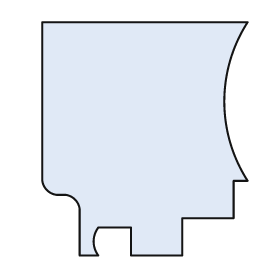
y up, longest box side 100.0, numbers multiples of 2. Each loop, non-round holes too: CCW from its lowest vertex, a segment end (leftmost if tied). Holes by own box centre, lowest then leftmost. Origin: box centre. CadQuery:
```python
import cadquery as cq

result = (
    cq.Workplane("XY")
    .moveTo(-28.0, -50.0)
    .lineTo(-20.0, -50.0)
    .threePointArc((-22.0, -44.0), (-20.0, -38.0))
    .lineTo(-6.0, -38.0)
    .lineTo(-6.0, -50.0)
    .lineTo(16.0, -50.0)
    .lineTo(16.0, -34.0)
    .lineTo(38.0, -34.0)
    .lineTo(38.0, -18.0)
    .lineTo(44.0, -18.0)
    .threePointArc((34.0, 16.0), (44.0, 50.0))
    .lineTo(-44.0, 50.0)
    .lineTo(-44.0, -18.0)
    .threePointArc((-42.0, -22.0), (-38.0, -24.0))
    .lineTo(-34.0, -24.0)
    .threePointArc((-30.0, -26.0), (-28.0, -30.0))
    .close()
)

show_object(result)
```